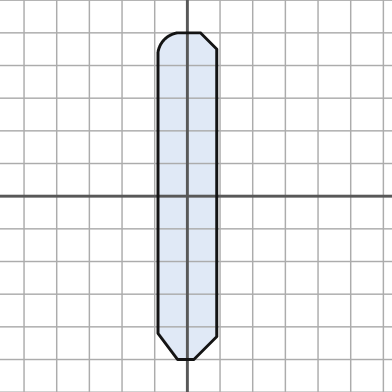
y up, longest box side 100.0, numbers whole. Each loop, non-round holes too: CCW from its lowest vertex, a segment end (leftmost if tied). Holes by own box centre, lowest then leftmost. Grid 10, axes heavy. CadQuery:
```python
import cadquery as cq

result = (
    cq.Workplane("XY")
    .moveTo(-3.0, -50.0)
    .lineTo(2.0, -50.0)
    .lineTo(9.0, -43.0)
    .lineTo(9.0, 45.0)
    .lineTo(4.0, 50.0)
    .lineTo(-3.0, 50.0)
    .threePointArc((-7.0, 48.0), (-9.0, 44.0))
    .lineTo(-9.0, -42.0)
    .close()
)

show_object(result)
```